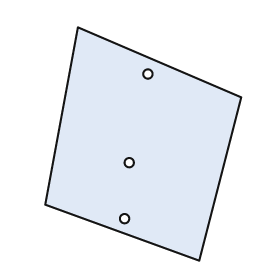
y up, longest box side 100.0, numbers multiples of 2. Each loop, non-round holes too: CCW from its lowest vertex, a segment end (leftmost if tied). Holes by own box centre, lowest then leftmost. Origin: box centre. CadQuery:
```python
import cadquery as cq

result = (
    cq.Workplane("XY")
    .moveTo(24.0, -50.0)
    .lineTo(42.0, 20.0)
    .lineTo(-28.0, 50.0)
    .lineTo(-42.0, -26.0)
    .close()
    .moveTo(-8.0, -32.0)
    .circle(2.0)
    .moveTo(-6.0, -8.0)
    .circle(2.0)
    .moveTo(2.0, 30.0)
    .circle(2.0)
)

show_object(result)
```